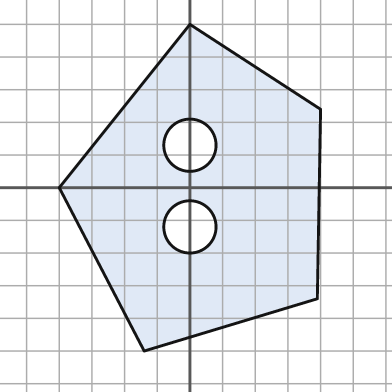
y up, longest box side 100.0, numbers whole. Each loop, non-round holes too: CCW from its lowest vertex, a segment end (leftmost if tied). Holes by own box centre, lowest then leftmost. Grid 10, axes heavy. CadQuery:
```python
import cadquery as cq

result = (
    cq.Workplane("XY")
    .moveTo(-14.0, -50.0)
    .lineTo(39.0, -34.0)
    .lineTo(40.0, 24.0)
    .lineTo(0.0, 50.0)
    .lineTo(-40.0, 0.0)
    .close()
    .moveTo(0.0, -12.0)
    .circle(8.0)
    .moveTo(0.0, 13.0)
    .circle(8.0)
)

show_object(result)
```